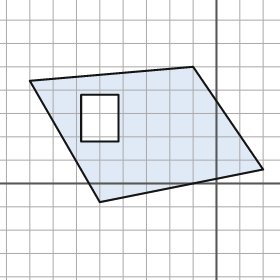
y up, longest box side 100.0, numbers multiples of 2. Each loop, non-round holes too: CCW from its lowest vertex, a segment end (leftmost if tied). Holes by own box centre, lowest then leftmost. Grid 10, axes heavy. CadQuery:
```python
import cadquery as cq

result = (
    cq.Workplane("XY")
    .moveTo(-50.0, -8.0)
    .lineTo(20.0, 6.0)
    .lineTo(-10.0, 50.0)
    .lineTo(-80.0, 44.0)
    .close()
    .moveTo(-58.0, 18.0)
    .lineTo(-42.0, 18.0)
    .lineTo(-42.0, 38.0)
    .lineTo(-58.0, 38.0)
    .close()
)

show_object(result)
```